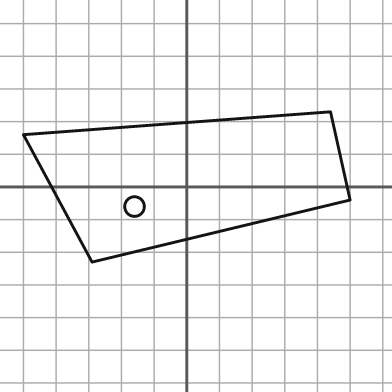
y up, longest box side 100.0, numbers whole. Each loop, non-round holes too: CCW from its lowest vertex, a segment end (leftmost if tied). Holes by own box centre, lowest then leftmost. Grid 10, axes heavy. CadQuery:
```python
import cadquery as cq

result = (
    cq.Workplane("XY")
    .moveTo(-29.0, -23.0)
    .lineTo(50.0, -4.0)
    .lineTo(44.0, 23.0)
    .lineTo(-50.0, 16.0)
    .close()
    .moveTo(-16.0, -6.0)
    .circle(3.0)
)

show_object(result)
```